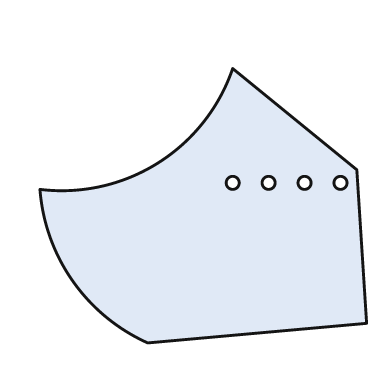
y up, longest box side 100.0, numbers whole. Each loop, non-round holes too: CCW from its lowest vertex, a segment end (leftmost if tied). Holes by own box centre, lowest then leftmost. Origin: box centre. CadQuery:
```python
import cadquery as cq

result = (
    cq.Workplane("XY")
    .moveTo(-17.0, -42.0)
    .lineTo(50.0, -36.0)
    .lineTo(47.0, 11.0)
    .lineTo(9.0, 42.0)
    .threePointArc((-14.0, 13.0), (-50.0, 5.0))
    .threePointArc((-40.0, -23.0), (-17.0, -42.0))
    .close()
    .moveTo(9.0, 7.0)
    .circle(2.0)
    .moveTo(20.0, 7.0)
    .circle(2.0)
    .moveTo(31.0, 7.0)
    .circle(2.0)
    .moveTo(42.0, 7.0)
    .circle(2.0)
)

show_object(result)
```